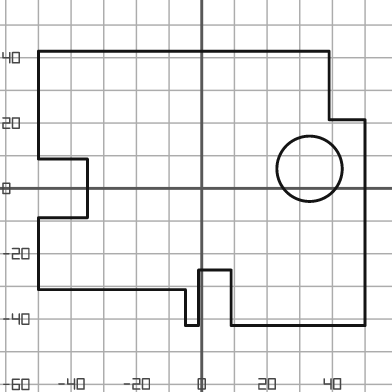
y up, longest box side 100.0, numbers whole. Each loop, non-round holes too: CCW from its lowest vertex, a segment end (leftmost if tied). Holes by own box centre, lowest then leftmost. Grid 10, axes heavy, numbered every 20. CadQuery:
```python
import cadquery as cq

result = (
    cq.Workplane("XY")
    .moveTo(-5.0, -42.0)
    .lineTo(-1.0, -42.0)
    .lineTo(-1.0, -25.0)
    .lineTo(9.0, -25.0)
    .lineTo(9.0, -42.0)
    .lineTo(50.0, -42.0)
    .lineTo(50.0, 21.0)
    .lineTo(39.0, 21.0)
    .lineTo(39.0, 42.0)
    .lineTo(-50.0, 42.0)
    .lineTo(-50.0, 9.0)
    .lineTo(-35.0, 9.0)
    .lineTo(-35.0, -9.0)
    .lineTo(-50.0, -9.0)
    .lineTo(-50.0, -31.0)
    .lineTo(-5.0, -31.0)
    .close()
    .moveTo(33.0, 6.0)
    .circle(10.0)
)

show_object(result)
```